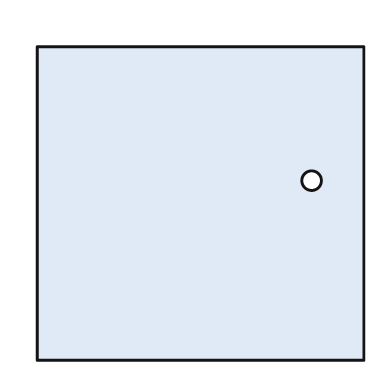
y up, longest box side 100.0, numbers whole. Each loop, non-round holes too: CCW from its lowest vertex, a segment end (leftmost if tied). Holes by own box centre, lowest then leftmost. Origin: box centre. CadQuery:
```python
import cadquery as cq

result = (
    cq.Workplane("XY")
    .moveTo(-50.0, -48.0)
    .lineTo(50.0, -48.0)
    .lineTo(50.0, 48.0)
    .lineTo(-50.0, 48.0)
    .close()
    .moveTo(34.0, 7.0)
    .circle(3.0)
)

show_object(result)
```